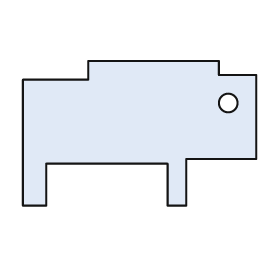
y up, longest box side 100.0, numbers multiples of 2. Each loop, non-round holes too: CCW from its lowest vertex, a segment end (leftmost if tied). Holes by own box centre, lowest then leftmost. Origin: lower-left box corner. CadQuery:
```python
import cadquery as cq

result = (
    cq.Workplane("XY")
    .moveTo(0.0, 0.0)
    .lineTo(10.0, 0.0)
    .lineTo(10.0, 18.0)
    .lineTo(62.0, 18.0)
    .lineTo(62.0, 0.0)
    .lineTo(70.0, 0.0)
    .lineTo(70.0, 20.0)
    .lineTo(100.0, 20.0)
    .lineTo(100.0, 56.0)
    .lineTo(84.0, 56.0)
    .lineTo(84.0, 62.0)
    .lineTo(28.0, 62.0)
    .lineTo(28.0, 54.0)
    .lineTo(0.0, 54.0)
    .close()
    .moveTo(88.0, 44.0)
    .circle(4.0)
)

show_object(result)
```